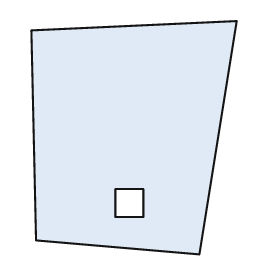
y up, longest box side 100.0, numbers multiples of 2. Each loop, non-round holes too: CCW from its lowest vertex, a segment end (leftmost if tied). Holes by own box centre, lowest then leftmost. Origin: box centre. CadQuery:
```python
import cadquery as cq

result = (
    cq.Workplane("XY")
    .moveTo(28.0, -50.0)
    .lineTo(44.0, 50.0)
    .lineTo(-44.0, 46.0)
    .lineTo(-42.0, -44.0)
    .close()
    .moveTo(-8.0, -34.0)
    .lineTo(4.0, -34.0)
    .lineTo(4.0, -22.0)
    .lineTo(-8.0, -22.0)
    .close()
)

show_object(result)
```